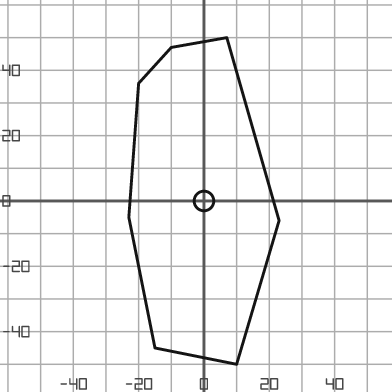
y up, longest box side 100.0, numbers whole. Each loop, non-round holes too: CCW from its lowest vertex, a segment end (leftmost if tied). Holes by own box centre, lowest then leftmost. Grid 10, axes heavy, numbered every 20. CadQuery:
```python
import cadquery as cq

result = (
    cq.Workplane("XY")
    .moveTo(10.0, -50.0)
    .lineTo(23.0, -6.0)
    .lineTo(7.0, 50.0)
    .lineTo(-10.0, 47.0)
    .lineTo(-20.0, 36.0)
    .lineTo(-23.0, -5.0)
    .lineTo(-15.0, -45.0)
    .close()
    .moveTo(0.0, 0.0)
    .circle(3.0)
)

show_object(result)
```